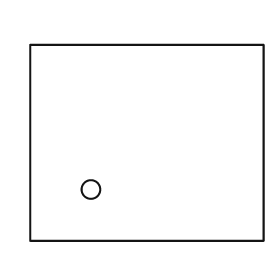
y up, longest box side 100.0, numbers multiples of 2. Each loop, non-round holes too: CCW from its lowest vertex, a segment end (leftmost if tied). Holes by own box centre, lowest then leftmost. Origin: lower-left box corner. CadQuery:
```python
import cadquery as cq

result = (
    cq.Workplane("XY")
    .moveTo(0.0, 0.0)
    .lineTo(100.0, 0.0)
    .lineTo(100.0, 84.0)
    .lineTo(0.0, 84.0)
    .close()
    .moveTo(26.0, 22.0)
    .circle(4.0)
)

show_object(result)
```